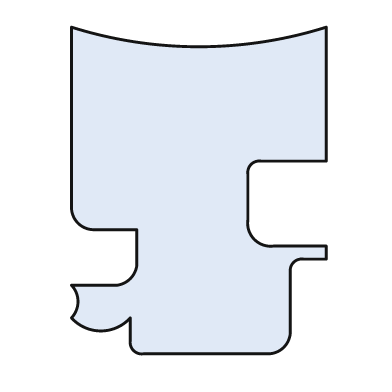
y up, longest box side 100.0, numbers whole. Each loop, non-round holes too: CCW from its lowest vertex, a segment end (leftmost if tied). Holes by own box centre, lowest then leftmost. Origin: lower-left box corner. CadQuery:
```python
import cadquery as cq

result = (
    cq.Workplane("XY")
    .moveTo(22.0, 0.0)
    .lineTo(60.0, 0.0)
    .threePointArc((65.0, 2.0), (67.0, 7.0))
    .lineTo(67.0, 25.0)
    .threePointArc((68.0, 28.0), (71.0, 29.0))
    .lineTo(78.0, 29.0)
    .lineTo(78.0, 33.0)
    .lineTo(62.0, 33.0)
    .threePointArc((56.0, 35.0), (54.0, 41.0))
    .lineTo(54.0, 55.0)
    .threePointArc((55.0, 58.0), (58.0, 59.0))
    .lineTo(78.0, 59.0)
    .lineTo(78.0, 100.0)
    .threePointArc((39.0, 94.0), (0.0, 100.0))
    .lineTo(0.0, 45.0)
    .threePointArc((2.0, 40.0), (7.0, 38.0))
    .lineTo(20.0, 38.0)
    .lineTo(20.0, 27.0)
    .threePointArc((18.0, 23.0), (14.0, 21.0))
    .lineTo(0.0, 21.0)
    .threePointArc((2.0, 16.0), (0.0, 11.0))
    .threePointArc((9.0, 7.0), (18.0, 11.0))
    .lineTo(18.0, 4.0)
    .threePointArc((19.0, 1.0), (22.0, 0.0))
    .close()
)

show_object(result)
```